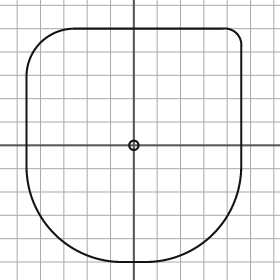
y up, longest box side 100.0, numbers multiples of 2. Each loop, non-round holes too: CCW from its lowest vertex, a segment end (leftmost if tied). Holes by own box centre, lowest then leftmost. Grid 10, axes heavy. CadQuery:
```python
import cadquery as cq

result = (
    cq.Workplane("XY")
    .moveTo(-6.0, -50.0)
    .lineTo(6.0, -50.0)
    .threePointArc((34.0, -38.0), (46.0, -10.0))
    .lineTo(46.0, 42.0)
    .threePointArc((44.0, 48.0), (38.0, 50.0))
    .lineTo(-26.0, 50.0)
    .threePointArc((-40.0, 44.0), (-46.0, 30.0))
    .lineTo(-46.0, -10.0)
    .threePointArc((-34.0, -38.0), (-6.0, -50.0))
    .close()
    .moveTo(0.0, 0.0)
    .circle(2.0)
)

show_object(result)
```